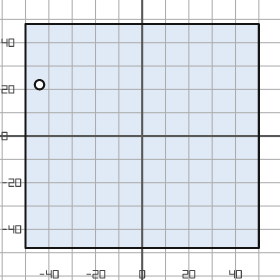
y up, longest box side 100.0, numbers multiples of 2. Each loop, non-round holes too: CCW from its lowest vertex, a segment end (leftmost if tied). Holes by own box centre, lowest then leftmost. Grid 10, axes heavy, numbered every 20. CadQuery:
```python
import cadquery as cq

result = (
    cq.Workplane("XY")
    .moveTo(-50.0, -48.0)
    .lineTo(50.0, -48.0)
    .lineTo(50.0, 48.0)
    .lineTo(-50.0, 48.0)
    .close()
    .moveTo(-44.0, 22.0)
    .circle(2.0)
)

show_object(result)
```